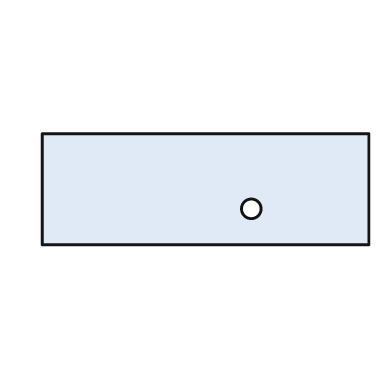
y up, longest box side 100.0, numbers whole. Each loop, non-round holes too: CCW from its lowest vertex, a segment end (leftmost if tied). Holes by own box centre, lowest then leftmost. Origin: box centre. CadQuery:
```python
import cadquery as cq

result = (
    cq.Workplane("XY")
    .moveTo(-50.0, -17.0)
    .lineTo(50.0, -17.0)
    .lineTo(50.0, 17.0)
    .lineTo(-50.0, 17.0)
    .close()
    .moveTo(14.0, -6.0)
    .circle(3.0)
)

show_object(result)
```